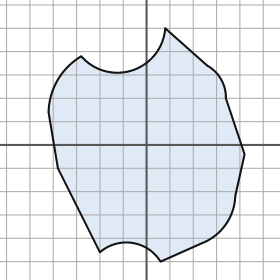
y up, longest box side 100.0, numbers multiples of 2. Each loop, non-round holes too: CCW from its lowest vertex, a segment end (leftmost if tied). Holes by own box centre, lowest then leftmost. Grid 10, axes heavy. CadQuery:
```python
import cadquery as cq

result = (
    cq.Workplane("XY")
    .moveTo(6.0, -50.0)
    .lineTo(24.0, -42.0)
    .threePointArc((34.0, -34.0), (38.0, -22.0))
    .lineTo(42.0, -4.0)
    .lineTo(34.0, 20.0)
    .threePointArc((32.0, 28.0), (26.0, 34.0))
    .lineTo(8.0, 50.0)
    .threePointArc((-6.0, 32.0), (-28.0, 38.0))
    .threePointArc((-38.0, 28.0), (-42.0, 14.0))
    .lineTo(-38.0, -10.0)
    .lineTo(-20.0, -46.0)
    .threePointArc((-6.0, -42.0), (6.0, -50.0))
    .close()
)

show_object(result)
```